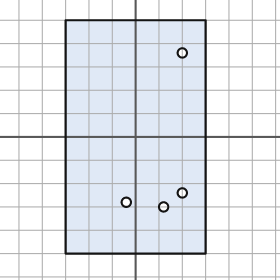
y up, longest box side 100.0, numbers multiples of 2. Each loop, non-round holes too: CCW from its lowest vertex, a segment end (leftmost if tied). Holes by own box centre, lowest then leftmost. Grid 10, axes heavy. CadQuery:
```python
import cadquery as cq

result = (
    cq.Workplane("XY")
    .moveTo(-30.0, -50.0)
    .lineTo(30.0, -50.0)
    .lineTo(30.0, 50.0)
    .lineTo(-30.0, 50.0)
    .close()
    .moveTo(12.0, -30.0)
    .circle(2.0)
    .moveTo(-4.0, -28.0)
    .circle(2.0)
    .moveTo(20.0, -24.0)
    .circle(2.0)
    .moveTo(20.0, 36.0)
    .circle(2.0)
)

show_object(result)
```